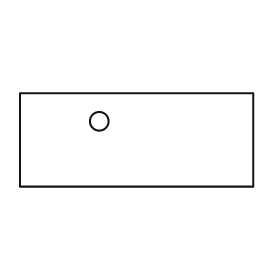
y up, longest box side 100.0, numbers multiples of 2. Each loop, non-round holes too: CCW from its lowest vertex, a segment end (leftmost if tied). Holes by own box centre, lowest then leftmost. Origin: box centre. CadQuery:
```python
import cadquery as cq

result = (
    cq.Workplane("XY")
    .moveTo(-50.0, -20.0)
    .lineTo(50.0, -20.0)
    .lineTo(50.0, 20.0)
    .lineTo(-50.0, 20.0)
    .close()
    .moveTo(-16.0, 8.0)
    .circle(4.0)
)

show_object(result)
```